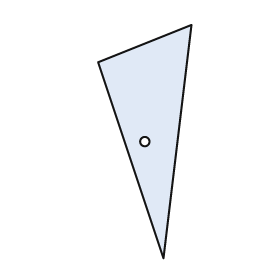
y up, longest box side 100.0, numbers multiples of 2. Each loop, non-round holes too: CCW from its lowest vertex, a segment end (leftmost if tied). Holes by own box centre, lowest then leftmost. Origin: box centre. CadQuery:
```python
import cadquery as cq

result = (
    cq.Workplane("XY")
    .moveTo(8.0, -50.0)
    .lineTo(20.0, 50.0)
    .lineTo(-20.0, 34.0)
    .close()
    .moveTo(0.0, 0.0)
    .circle(2.0)
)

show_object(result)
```